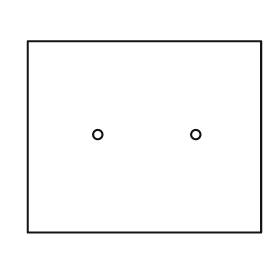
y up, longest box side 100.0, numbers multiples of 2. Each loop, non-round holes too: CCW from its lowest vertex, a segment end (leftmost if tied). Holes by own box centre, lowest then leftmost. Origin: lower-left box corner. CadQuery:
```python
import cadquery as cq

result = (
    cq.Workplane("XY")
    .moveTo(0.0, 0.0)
    .lineTo(100.0, 0.0)
    .lineTo(100.0, 82.0)
    .lineTo(0.0, 82.0)
    .close()
    .moveTo(30.0, 42.0)
    .circle(2.0)
    .moveTo(72.0, 42.0)
    .circle(2.0)
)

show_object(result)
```